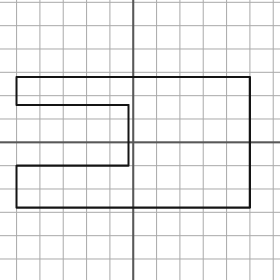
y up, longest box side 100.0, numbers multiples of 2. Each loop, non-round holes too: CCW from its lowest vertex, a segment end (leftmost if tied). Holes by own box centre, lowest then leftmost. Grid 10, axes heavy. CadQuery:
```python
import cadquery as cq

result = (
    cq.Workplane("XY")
    .moveTo(-50.0, -28.0)
    .lineTo(50.0, -28.0)
    .lineTo(50.0, 28.0)
    .lineTo(-50.0, 28.0)
    .lineTo(-50.0, 16.0)
    .lineTo(-2.0, 16.0)
    .lineTo(-2.0, -10.0)
    .lineTo(-50.0, -10.0)
    .close()
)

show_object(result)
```